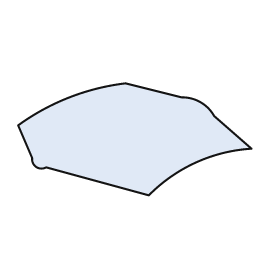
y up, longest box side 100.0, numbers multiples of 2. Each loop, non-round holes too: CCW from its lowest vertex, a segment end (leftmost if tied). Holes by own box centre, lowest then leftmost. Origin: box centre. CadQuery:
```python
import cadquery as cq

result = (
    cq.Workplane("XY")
    .moveTo(6.0, -24.0)
    .threePointArc((26.0, -10.0), (50.0, -4.0))
    .lineTo(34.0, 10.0)
    .threePointArc((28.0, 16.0), (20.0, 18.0))
    .lineTo(-4.0, 24.0)
    .threePointArc((-28.0, 18.0), (-50.0, 6.0))
    .lineTo(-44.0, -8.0)
    .threePointArc((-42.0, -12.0), (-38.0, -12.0))
    .close()
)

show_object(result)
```